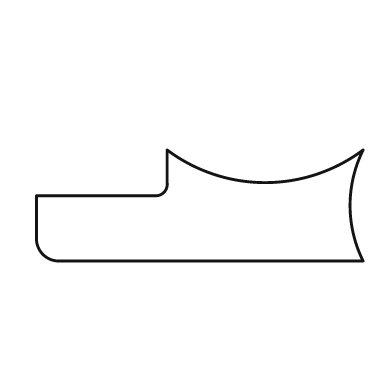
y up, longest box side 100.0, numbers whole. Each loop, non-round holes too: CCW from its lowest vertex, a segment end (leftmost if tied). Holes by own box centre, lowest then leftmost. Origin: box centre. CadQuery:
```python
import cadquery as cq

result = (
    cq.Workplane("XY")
    .moveTo(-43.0, -17.0)
    .lineTo(50.0, -17.0)
    .threePointArc((46.0, 0.0), (50.0, 17.0))
    .threePointArc((20.0, 7.0), (-10.0, 17.0))
    .lineTo(-10.0, 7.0)
    .threePointArc((-11.0, 4.0), (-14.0, 3.0))
    .lineTo(-50.0, 3.0)
    .lineTo(-50.0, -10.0)
    .threePointArc((-48.0, -15.0), (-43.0, -17.0))
    .close()
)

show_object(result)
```